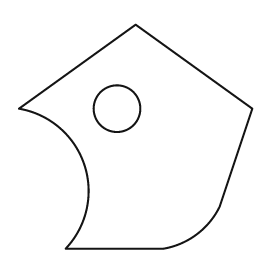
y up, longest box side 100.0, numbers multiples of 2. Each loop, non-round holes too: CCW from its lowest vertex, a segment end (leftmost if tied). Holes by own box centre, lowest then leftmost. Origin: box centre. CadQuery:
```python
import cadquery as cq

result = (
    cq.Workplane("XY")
    .moveTo(-30.0, -48.0)
    .lineTo(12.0, -48.0)
    .threePointArc((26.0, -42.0), (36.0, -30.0))
    .lineTo(50.0, 12.0)
    .lineTo(0.0, 48.0)
    .lineTo(-50.0, 12.0)
    .threePointArc((-22.0, -12.0), (-30.0, -48.0))
    .close()
    .moveTo(-8.0, 12.0)
    .circle(10.0)
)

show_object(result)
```